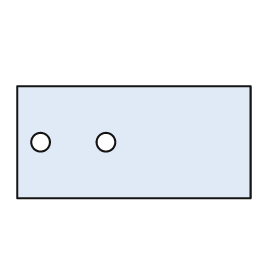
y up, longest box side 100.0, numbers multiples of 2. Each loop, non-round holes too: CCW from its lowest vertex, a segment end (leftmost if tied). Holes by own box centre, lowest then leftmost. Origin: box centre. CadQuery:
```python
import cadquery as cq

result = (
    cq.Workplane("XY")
    .moveTo(-50.0, -24.0)
    .lineTo(50.0, -24.0)
    .lineTo(50.0, 24.0)
    .lineTo(-50.0, 24.0)
    .close()
    .moveTo(-40.0, 0.0)
    .circle(4.0)
    .moveTo(-12.0, 0.0)
    .circle(4.0)
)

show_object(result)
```